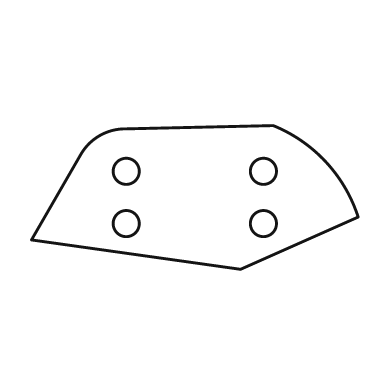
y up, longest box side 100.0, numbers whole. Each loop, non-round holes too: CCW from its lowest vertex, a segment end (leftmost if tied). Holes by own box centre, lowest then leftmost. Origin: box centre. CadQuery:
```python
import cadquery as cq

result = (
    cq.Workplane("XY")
    .moveTo(14.0, -22.0)
    .lineTo(50.0, -6.0)
    .threePointArc((40.0, 11.0), (24.0, 22.0))
    .lineTo(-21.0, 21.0)
    .threePointArc((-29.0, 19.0), (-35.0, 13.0))
    .lineTo(-50.0, -13.0)
    .close()
    .moveTo(-21.0, -8.0)
    .circle(4.0)
    .moveTo(21.0, -8.0)
    .circle(4.0)
    .moveTo(-21.0, 8.0)
    .circle(4.0)
    .moveTo(21.0, 8.0)
    .circle(4.0)
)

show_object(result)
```